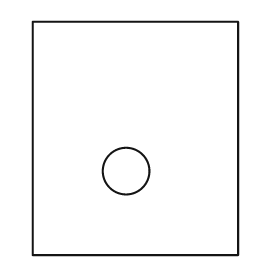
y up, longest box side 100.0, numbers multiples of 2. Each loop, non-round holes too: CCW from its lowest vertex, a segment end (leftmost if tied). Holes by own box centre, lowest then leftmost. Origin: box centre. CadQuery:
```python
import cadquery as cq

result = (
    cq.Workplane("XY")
    .moveTo(-44.0, -50.0)
    .lineTo(44.0, -50.0)
    .lineTo(44.0, 50.0)
    .lineTo(-44.0, 50.0)
    .close()
    .moveTo(-4.0, -14.0)
    .circle(10.0)
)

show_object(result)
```